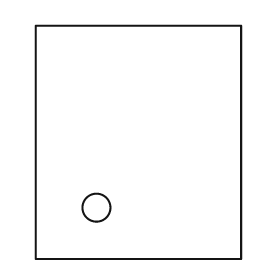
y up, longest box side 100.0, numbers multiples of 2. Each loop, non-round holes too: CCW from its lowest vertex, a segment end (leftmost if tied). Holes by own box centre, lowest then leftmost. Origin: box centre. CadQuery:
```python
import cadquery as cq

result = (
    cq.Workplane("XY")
    .moveTo(-44.0, -50.0)
    .lineTo(44.0, -50.0)
    .lineTo(44.0, 50.0)
    .lineTo(-44.0, 50.0)
    .close()
    .moveTo(-18.0, -28.0)
    .circle(6.0)
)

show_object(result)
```